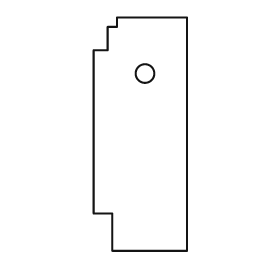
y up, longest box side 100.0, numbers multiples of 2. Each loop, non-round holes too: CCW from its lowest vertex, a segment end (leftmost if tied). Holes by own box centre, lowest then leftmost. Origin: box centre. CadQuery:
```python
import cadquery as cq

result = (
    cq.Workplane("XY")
    .moveTo(-12.0, -50.0)
    .lineTo(20.0, -50.0)
    .lineTo(20.0, 50.0)
    .lineTo(-10.0, 50.0)
    .lineTo(-10.0, 46.0)
    .lineTo(-14.0, 46.0)
    .lineTo(-14.0, 36.0)
    .lineTo(-20.0, 36.0)
    .lineTo(-20.0, -34.0)
    .lineTo(-12.0, -34.0)
    .close()
    .moveTo(2.0, 26.0)
    .circle(4.0)
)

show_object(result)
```